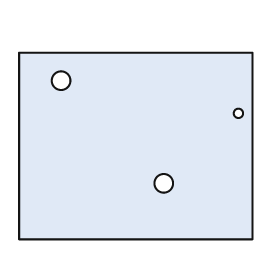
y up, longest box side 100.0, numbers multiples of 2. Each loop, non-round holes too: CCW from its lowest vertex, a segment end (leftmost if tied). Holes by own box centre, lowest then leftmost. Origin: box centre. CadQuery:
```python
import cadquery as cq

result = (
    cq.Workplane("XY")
    .moveTo(-50.0, -40.0)
    .lineTo(50.0, -40.0)
    .lineTo(50.0, 40.0)
    .lineTo(-50.0, 40.0)
    .close()
    .moveTo(12.0, -16.0)
    .circle(4.0)
    .moveTo(44.0, 14.0)
    .circle(2.0)
    .moveTo(-32.0, 28.0)
    .circle(4.0)
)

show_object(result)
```